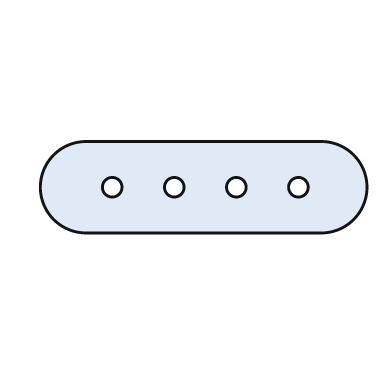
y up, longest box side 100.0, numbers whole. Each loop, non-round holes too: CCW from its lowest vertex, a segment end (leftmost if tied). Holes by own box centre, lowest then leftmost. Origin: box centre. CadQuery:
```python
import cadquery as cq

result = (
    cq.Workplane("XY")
    .moveTo(-36.0, -14.0)
    .lineTo(36.0, -14.0)
    .threePointArc((50.0, 0.0), (36.0, 14.0))
    .lineTo(-36.0, 14.0)
    .threePointArc((-50.0, 0.0), (-36.0, -14.0))
    .close()
    .moveTo(-28.0, 0.0)
    .circle(3.0)
    .moveTo(-9.0, 0.0)
    .circle(3.0)
    .moveTo(10.0, 0.0)
    .circle(3.0)
    .moveTo(29.0, 0.0)
    .circle(3.0)
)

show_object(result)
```